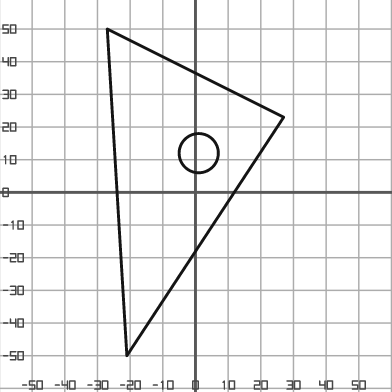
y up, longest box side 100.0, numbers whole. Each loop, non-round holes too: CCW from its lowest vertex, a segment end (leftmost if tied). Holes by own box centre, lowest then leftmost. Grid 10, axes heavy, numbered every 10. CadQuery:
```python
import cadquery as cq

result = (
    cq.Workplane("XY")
    .moveTo(-21.0, -50.0)
    .lineTo(27.0, 23.0)
    .lineTo(-27.0, 50.0)
    .close()
    .moveTo(1.0, 12.0)
    .circle(6.0)
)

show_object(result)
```